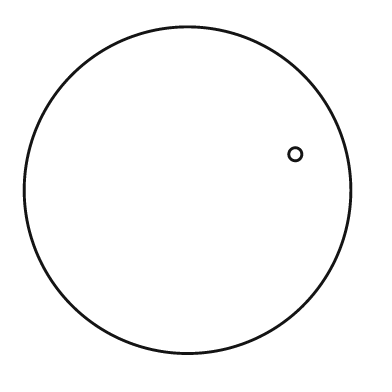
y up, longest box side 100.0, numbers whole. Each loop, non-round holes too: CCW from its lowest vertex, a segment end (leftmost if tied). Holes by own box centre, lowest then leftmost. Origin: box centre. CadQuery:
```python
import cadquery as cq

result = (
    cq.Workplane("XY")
    .moveTo(0.0, 0.0)
    .circle(50.0)
    .moveTo(33.0, 11.0)
    .circle(2.0)
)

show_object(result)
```